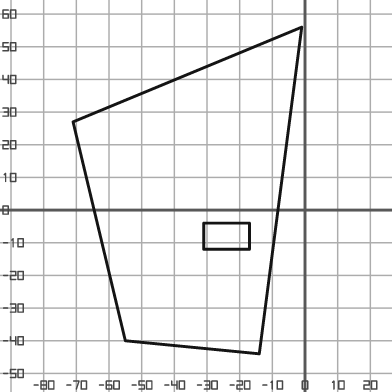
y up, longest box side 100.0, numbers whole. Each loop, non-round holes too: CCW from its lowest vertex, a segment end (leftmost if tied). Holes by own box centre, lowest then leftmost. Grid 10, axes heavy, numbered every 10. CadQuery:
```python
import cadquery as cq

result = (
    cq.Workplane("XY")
    .moveTo(-14.0, -44.0)
    .lineTo(-1.0, 56.0)
    .lineTo(-71.0, 27.0)
    .lineTo(-55.0, -40.0)
    .close()
    .moveTo(-31.0, -12.0)
    .lineTo(-17.0, -12.0)
    .lineTo(-17.0, -4.0)
    .lineTo(-31.0, -4.0)
    .close()
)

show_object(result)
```